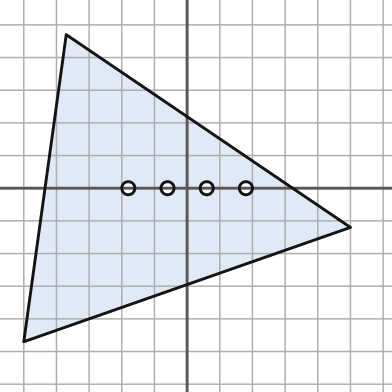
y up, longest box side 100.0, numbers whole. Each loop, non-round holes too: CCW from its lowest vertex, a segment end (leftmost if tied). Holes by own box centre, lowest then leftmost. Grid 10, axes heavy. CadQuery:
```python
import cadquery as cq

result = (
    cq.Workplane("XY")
    .moveTo(-50.0, -47.0)
    .lineTo(50.0, -12.0)
    .lineTo(-37.0, 47.0)
    .close()
    .moveTo(-18.0, 0.0)
    .circle(2.0)
    .moveTo(-6.0, 0.0)
    .circle(2.0)
    .moveTo(6.0, 0.0)
    .circle(2.0)
    .moveTo(18.0, 0.0)
    .circle(2.0)
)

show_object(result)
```